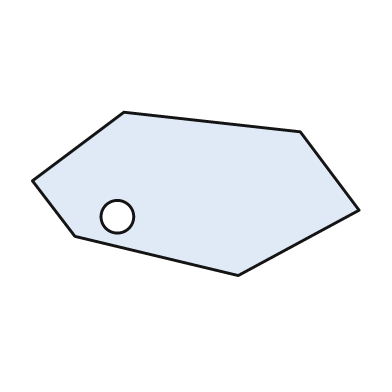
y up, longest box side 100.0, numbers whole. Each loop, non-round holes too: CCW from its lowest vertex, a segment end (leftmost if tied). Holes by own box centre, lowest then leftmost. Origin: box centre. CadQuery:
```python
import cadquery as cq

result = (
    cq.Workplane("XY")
    .moveTo(13.0, -25.0)
    .lineTo(50.0, -5.0)
    .lineTo(32.0, 19.0)
    .lineTo(-22.0, 25.0)
    .lineTo(-50.0, 4.0)
    .lineTo(-37.0, -13.0)
    .close()
    .moveTo(-24.0, -7.0)
    .circle(5.0)
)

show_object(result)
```